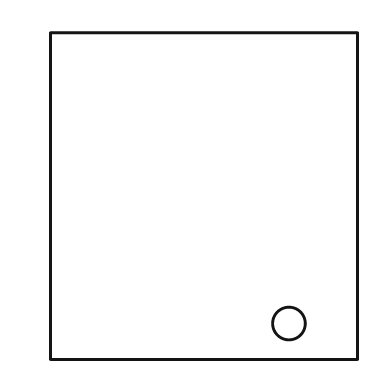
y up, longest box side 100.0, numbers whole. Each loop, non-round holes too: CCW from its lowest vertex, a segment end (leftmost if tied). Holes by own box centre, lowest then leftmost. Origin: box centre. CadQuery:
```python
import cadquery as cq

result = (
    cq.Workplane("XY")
    .moveTo(-47.0, -50.0)
    .lineTo(47.0, -50.0)
    .lineTo(47.0, 50.0)
    .lineTo(-47.0, 50.0)
    .close()
    .moveTo(26.0, -39.0)
    .circle(5.0)
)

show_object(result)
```